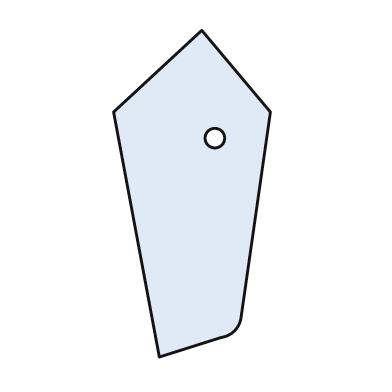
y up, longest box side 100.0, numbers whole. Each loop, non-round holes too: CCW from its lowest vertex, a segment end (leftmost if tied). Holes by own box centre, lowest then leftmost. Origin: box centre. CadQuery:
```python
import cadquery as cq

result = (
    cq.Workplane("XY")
    .moveTo(-10.0, -50.0)
    .lineTo(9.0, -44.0)
    .threePointArc((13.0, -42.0), (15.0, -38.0))
    .lineTo(24.0, 25.0)
    .lineTo(3.0, 50.0)
    .lineTo(-24.0, 25.0)
    .close()
    .moveTo(7.0, 17.0)
    .circle(3.0)
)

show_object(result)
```